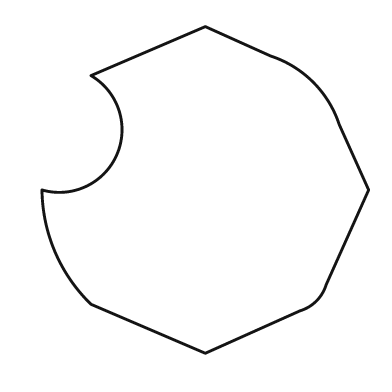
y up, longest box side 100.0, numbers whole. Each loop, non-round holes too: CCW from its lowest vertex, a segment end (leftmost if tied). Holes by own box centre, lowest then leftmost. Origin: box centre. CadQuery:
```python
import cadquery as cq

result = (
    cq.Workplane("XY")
    .moveTo(0.0, -50.0)
    .lineTo(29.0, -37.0)
    .threePointArc((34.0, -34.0), (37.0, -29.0))
    .lineTo(50.0, 0.0)
    .lineTo(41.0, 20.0)
    .threePointArc((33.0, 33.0), (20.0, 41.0))
    .lineTo(0.0, 50.0)
    .lineTo(-35.0, 35.0)
    .threePointArc((-27.0, 11.0), (-50.0, 0.0))
    .threePointArc((-46.0, -19.0), (-35.0, -35.0))
    .close()
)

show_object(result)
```